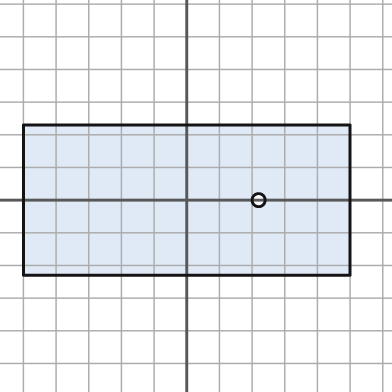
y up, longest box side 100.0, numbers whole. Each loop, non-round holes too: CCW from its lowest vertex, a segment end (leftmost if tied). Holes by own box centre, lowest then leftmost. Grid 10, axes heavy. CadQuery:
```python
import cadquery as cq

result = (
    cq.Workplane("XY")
    .moveTo(-50.0, -23.0)
    .lineTo(50.0, -23.0)
    .lineTo(50.0, 23.0)
    .lineTo(-50.0, 23.0)
    .close()
    .moveTo(22.0, 0.0)
    .circle(2.0)
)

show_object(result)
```